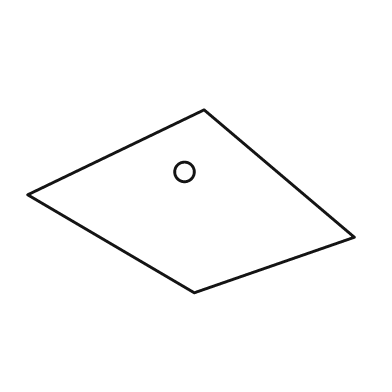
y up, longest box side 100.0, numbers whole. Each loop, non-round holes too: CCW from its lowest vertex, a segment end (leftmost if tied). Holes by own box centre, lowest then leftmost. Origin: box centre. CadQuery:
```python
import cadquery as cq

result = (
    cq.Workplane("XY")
    .moveTo(1.0, -28.0)
    .lineTo(50.0, -11.0)
    .lineTo(4.0, 28.0)
    .lineTo(-50.0, 2.0)
    .close()
    .moveTo(-2.0, 9.0)
    .circle(3.0)
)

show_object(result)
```